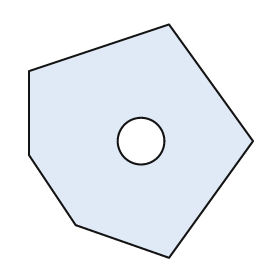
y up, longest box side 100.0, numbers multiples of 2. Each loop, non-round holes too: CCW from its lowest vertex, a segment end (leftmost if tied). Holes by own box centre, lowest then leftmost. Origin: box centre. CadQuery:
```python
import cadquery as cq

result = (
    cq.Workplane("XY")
    .moveTo(12.0, -50.0)
    .lineTo(48.0, 0.0)
    .lineTo(12.0, 50.0)
    .lineTo(-48.0, 30.0)
    .lineTo(-48.0, -6.0)
    .lineTo(-28.0, -36.0)
    .close()
    .moveTo(0.0, 0.0)
    .circle(10.0)
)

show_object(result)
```